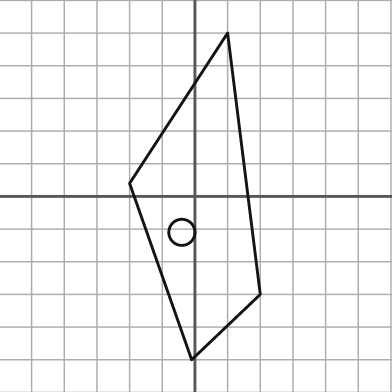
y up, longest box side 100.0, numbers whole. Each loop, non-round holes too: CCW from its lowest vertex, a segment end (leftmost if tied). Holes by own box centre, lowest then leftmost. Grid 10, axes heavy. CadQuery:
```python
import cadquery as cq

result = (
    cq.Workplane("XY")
    .moveTo(-1.0, -50.0)
    .lineTo(20.0, -30.0)
    .lineTo(10.0, 50.0)
    .lineTo(-20.0, 4.0)
    .close()
    .moveTo(-4.0, -11.0)
    .circle(4.0)
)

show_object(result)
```